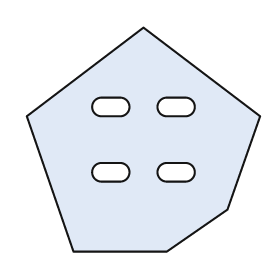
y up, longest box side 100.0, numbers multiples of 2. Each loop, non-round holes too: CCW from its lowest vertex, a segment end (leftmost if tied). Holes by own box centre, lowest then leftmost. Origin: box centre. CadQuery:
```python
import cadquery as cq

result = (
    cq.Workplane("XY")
    .moveTo(-30.0, -48.0)
    .lineTo(10.0, -48.0)
    .lineTo(36.0, -30.0)
    .lineTo(50.0, 10.0)
    .lineTo(0.0, 48.0)
    .lineTo(-50.0, 10.0)
    .close()
    .moveTo(-18.0, -18.0)
    .lineTo(-10.0, -18.0)
    .threePointArc((-6.0, -14.0), (-10.0, -10.0))
    .lineTo(-18.0, -10.0)
    .threePointArc((-22.0, -14.0), (-18.0, -18.0))
    .close()
    .moveTo(10.0, -18.0)
    .lineTo(18.0, -18.0)
    .threePointArc((22.0, -14.0), (18.0, -10.0))
    .lineTo(10.0, -10.0)
    .threePointArc((6.0, -14.0), (10.0, -18.0))
    .close()
    .moveTo(-18.0, 10.0)
    .lineTo(-10.0, 10.0)
    .threePointArc((-6.0, 14.0), (-10.0, 18.0))
    .lineTo(-18.0, 18.0)
    .threePointArc((-22.0, 14.0), (-18.0, 10.0))
    .close()
    .moveTo(10.0, 10.0)
    .lineTo(18.0, 10.0)
    .threePointArc((22.0, 14.0), (18.0, 18.0))
    .lineTo(10.0, 18.0)
    .threePointArc((6.0, 14.0), (10.0, 10.0))
    .close()
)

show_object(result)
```